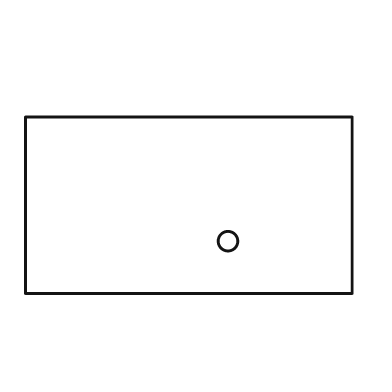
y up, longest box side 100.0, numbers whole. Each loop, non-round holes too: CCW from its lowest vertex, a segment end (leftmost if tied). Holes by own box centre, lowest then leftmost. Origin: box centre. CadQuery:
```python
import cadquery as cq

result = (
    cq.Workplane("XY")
    .moveTo(-50.0, -27.0)
    .lineTo(50.0, -27.0)
    .lineTo(50.0, 27.0)
    .lineTo(-50.0, 27.0)
    .close()
    .moveTo(12.0, -11.0)
    .circle(3.0)
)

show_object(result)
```